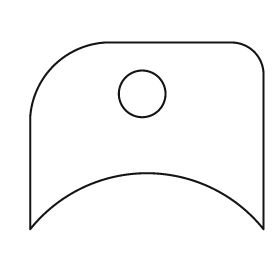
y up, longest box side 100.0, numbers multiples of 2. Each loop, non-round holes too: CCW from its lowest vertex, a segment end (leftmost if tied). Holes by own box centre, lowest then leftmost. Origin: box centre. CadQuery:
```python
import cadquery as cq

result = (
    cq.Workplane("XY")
    .moveTo(-50.0, -40.0)
    .threePointArc((0.0, -16.0), (50.0, -40.0))
    .lineTo(50.0, 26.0)
    .threePointArc((46.0, 36.0), (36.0, 40.0))
    .lineTo(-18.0, 40.0)
    .threePointArc((-40.0, 30.0), (-50.0, 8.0))
    .close()
    .moveTo(-2.0, 18.0)
    .circle(10.0)
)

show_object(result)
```